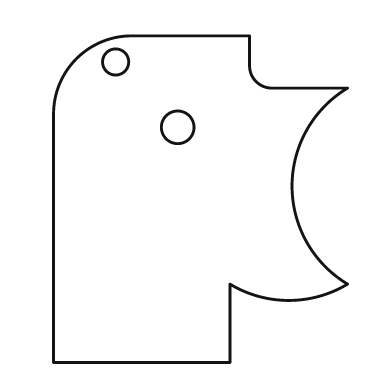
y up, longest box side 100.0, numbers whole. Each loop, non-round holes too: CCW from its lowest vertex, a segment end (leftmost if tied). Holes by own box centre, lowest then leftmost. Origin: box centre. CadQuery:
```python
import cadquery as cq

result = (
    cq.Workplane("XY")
    .moveTo(-45.0, -50.0)
    .lineTo(9.0, -50.0)
    .lineTo(9.0, -26.0)
    .threePointArc((27.0, -31.0), (45.0, -26.0))
    .threePointArc((28.0, 4.0), (45.0, 34.0))
    .lineTo(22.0, 34.0)
    .threePointArc((17.0, 36.0), (15.0, 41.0))
    .lineTo(15.0, 50.0)
    .lineTo(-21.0, 50.0)
    .threePointArc((-38.0, 43.0), (-45.0, 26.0))
    .close()
    .moveTo(-7.0, 22.0)
    .circle(5.0)
    .moveTo(-26.0, 42.0)
    .circle(4.0)
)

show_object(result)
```